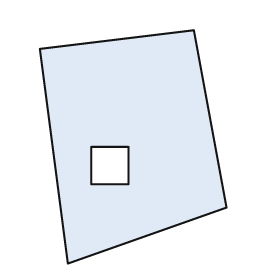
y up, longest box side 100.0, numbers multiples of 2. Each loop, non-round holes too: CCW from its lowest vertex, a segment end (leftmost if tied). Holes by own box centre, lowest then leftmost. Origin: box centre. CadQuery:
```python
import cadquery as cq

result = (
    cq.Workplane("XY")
    .moveTo(-28.0, -50.0)
    .lineTo(40.0, -26.0)
    .lineTo(26.0, 50.0)
    .lineTo(-40.0, 42.0)
    .close()
    .moveTo(-18.0, -16.0)
    .lineTo(-2.0, -16.0)
    .lineTo(-2.0, 0.0)
    .lineTo(-18.0, 0.0)
    .close()
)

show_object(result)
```